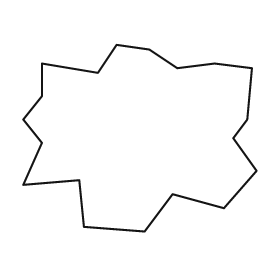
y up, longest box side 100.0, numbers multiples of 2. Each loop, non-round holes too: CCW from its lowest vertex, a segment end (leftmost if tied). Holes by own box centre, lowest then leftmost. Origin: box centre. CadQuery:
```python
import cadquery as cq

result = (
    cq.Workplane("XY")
    .moveTo(2.0, -40.0)
    .lineTo(14.0, -24.0)
    .lineTo(36.0, -30.0)
    .lineTo(50.0, -14.0)
    .lineTo(40.0, 0.0)
    .lineTo(46.0, 8.0)
    .lineTo(48.0, 30.0)
    .lineTo(32.0, 32.0)
    .lineTo(16.0, 30.0)
    .lineTo(4.0, 38.0)
    .lineTo(-10.0, 40.0)
    .lineTo(-18.0, 28.0)
    .lineTo(-42.0, 32.0)
    .lineTo(-42.0, 18.0)
    .lineTo(-50.0, 8.0)
    .lineTo(-42.0, -2.0)
    .lineTo(-50.0, -20.0)
    .lineTo(-26.0, -18.0)
    .lineTo(-24.0, -38.0)
    .close()
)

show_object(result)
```